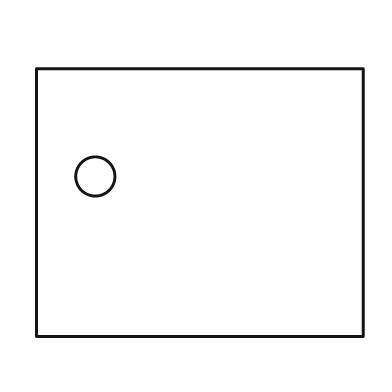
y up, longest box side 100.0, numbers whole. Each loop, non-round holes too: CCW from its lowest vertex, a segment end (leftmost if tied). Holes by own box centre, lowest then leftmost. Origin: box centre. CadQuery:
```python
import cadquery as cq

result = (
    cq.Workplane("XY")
    .moveTo(-50.0, -41.0)
    .lineTo(50.0, -41.0)
    .lineTo(50.0, 41.0)
    .lineTo(-50.0, 41.0)
    .close()
    .moveTo(-32.0, 8.0)
    .circle(6.0)
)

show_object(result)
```